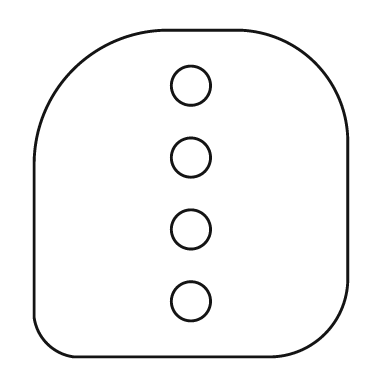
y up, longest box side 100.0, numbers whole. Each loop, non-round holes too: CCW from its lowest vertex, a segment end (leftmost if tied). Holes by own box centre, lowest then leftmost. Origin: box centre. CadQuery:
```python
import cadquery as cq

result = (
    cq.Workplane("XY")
    .moveTo(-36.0, -50.0)
    .lineTo(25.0, -50.0)
    .threePointArc((41.0, -43.0), (48.0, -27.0))
    .lineTo(48.0, 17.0)
    .threePointArc((38.0, 40.0), (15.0, 50.0))
    .lineTo(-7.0, 50.0)
    .threePointArc((-36.0, 38.0), (-48.0, 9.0))
    .lineTo(-48.0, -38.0)
    .threePointArc((-44.0, -46.0), (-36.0, -50.0))
    .close()
    .moveTo(0.0, -33.0)
    .circle(6.0)
    .moveTo(0.0, -11.0)
    .circle(6.0)
    .moveTo(0.0, 11.0)
    .circle(6.0)
    .moveTo(0.0, 33.0)
    .circle(6.0)
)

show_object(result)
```